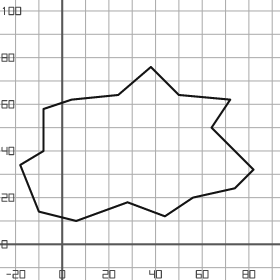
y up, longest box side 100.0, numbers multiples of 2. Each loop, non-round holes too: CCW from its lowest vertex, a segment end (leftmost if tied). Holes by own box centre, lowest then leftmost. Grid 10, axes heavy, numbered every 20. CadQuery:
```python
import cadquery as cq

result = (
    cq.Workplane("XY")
    .moveTo(6.0, 10.0)
    .lineTo(28.0, 18.0)
    .lineTo(44.0, 12.0)
    .lineTo(56.0, 20.0)
    .lineTo(74.0, 24.0)
    .lineTo(82.0, 32.0)
    .lineTo(64.0, 50.0)
    .lineTo(72.0, 62.0)
    .lineTo(50.0, 64.0)
    .lineTo(38.0, 76.0)
    .lineTo(24.0, 64.0)
    .lineTo(4.0, 62.0)
    .lineTo(-8.0, 58.0)
    .lineTo(-8.0, 40.0)
    .lineTo(-18.0, 34.0)
    .lineTo(-10.0, 14.0)
    .close()
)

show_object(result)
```